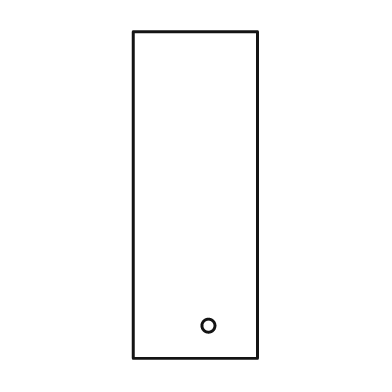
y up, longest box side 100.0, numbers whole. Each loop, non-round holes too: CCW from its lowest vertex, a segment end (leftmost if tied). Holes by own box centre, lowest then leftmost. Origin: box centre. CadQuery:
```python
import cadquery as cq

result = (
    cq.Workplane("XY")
    .moveTo(-19.0, -50.0)
    .lineTo(19.0, -50.0)
    .lineTo(19.0, 50.0)
    .lineTo(-19.0, 50.0)
    .close()
    .moveTo(4.0, -40.0)
    .circle(2.0)
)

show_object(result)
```